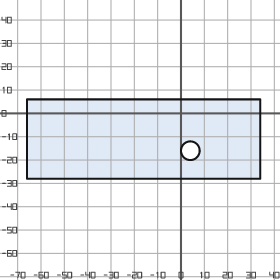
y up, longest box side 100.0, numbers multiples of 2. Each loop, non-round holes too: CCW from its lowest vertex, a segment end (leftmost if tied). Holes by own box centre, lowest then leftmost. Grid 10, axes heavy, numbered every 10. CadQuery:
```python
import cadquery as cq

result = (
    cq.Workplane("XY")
    .moveTo(-66.0, -28.0)
    .lineTo(34.0, -28.0)
    .lineTo(34.0, 6.0)
    .lineTo(-66.0, 6.0)
    .close()
    .moveTo(4.0, -16.0)
    .circle(4.0)
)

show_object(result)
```